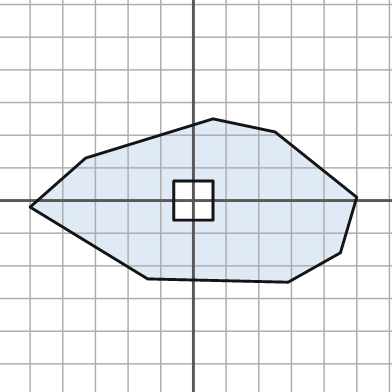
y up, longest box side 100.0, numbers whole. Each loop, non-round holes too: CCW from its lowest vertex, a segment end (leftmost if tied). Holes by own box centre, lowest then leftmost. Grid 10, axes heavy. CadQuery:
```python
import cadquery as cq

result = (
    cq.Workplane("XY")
    .moveTo(29.0, -25.0)
    .lineTo(45.0, -16.0)
    .lineTo(50.0, 1.0)
    .lineTo(25.0, 21.0)
    .lineTo(6.0, 25.0)
    .lineTo(-33.0, 13.0)
    .lineTo(-50.0, -2.0)
    .lineTo(-14.0, -24.0)
    .close()
    .moveTo(-6.0, -6.0)
    .lineTo(6.0, -6.0)
    .lineTo(6.0, 6.0)
    .lineTo(-6.0, 6.0)
    .close()
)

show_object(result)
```